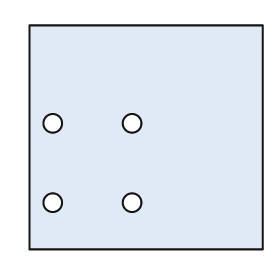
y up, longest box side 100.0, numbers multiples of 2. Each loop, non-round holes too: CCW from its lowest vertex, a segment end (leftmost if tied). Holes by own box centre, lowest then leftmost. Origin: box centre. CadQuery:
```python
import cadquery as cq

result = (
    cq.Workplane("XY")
    .moveTo(-50.0, -48.0)
    .lineTo(50.0, -48.0)
    .lineTo(50.0, 48.0)
    .lineTo(-50.0, 48.0)
    .close()
    .moveTo(-40.0, -28.0)
    .circle(4.0)
    .moveTo(-6.0, -28.0)
    .circle(4.0)
    .moveTo(-40.0, 6.0)
    .circle(4.0)
    .moveTo(-6.0, 6.0)
    .circle(4.0)
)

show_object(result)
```